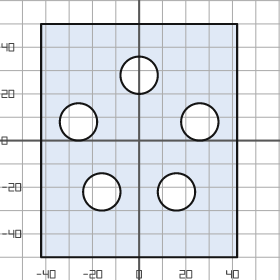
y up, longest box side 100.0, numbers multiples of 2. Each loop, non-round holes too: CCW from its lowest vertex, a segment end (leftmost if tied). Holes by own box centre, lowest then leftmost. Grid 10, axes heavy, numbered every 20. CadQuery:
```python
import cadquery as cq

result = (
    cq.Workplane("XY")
    .moveTo(-42.0, -50.0)
    .lineTo(42.0, -50.0)
    .lineTo(42.0, 50.0)
    .lineTo(-42.0, 50.0)
    .close()
    .moveTo(-16.0, -22.0)
    .circle(8.0)
    .moveTo(16.0, -22.0)
    .circle(8.0)
    .moveTo(-26.0, 8.0)
    .circle(8.0)
    .moveTo(26.0, 8.0)
    .circle(8.0)
    .moveTo(0.0, 28.0)
    .circle(8.0)
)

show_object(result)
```